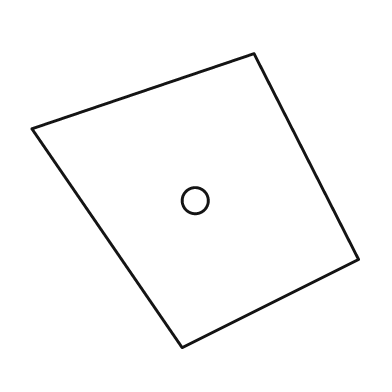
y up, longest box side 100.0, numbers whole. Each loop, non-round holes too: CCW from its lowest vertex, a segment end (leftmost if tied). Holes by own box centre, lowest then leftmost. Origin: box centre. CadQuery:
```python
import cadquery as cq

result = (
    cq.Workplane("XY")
    .moveTo(-4.0, -45.0)
    .lineTo(50.0, -18.0)
    .lineTo(18.0, 45.0)
    .lineTo(-50.0, 22.0)
    .close()
    .moveTo(0.0, 0.0)
    .circle(4.0)
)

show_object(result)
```